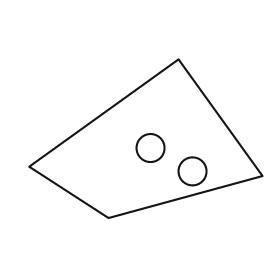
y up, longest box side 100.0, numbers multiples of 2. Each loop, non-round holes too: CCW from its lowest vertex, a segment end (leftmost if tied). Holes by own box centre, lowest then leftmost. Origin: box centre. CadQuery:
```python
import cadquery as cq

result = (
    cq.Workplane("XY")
    .moveTo(-16.0, -34.0)
    .lineTo(50.0, -16.0)
    .lineTo(14.0, 34.0)
    .lineTo(-50.0, -12.0)
    .close()
    .moveTo(20.0, -14.0)
    .circle(6.0)
    .moveTo(2.0, -4.0)
    .circle(6.0)
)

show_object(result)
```